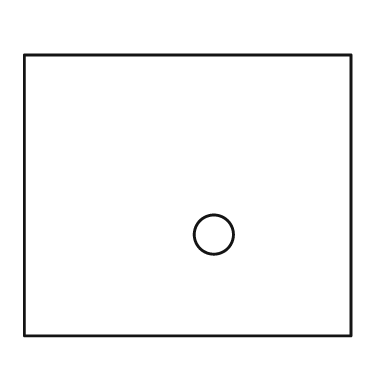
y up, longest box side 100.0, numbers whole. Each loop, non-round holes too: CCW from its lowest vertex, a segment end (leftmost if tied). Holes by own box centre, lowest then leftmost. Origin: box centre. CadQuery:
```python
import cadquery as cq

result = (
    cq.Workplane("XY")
    .moveTo(-50.0, -43.0)
    .lineTo(50.0, -43.0)
    .lineTo(50.0, 43.0)
    .lineTo(-50.0, 43.0)
    .close()
    .moveTo(8.0, -12.0)
    .circle(6.0)
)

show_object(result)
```